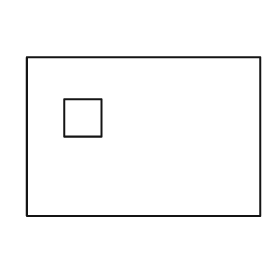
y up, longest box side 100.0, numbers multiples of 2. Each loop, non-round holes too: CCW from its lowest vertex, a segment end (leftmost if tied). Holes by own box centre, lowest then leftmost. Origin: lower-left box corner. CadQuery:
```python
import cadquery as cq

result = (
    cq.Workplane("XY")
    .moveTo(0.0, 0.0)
    .lineTo(100.0, 0.0)
    .lineTo(100.0, 68.0)
    .lineTo(0.0, 68.0)
    .close()
    .moveTo(16.0, 34.0)
    .lineTo(32.0, 34.0)
    .lineTo(32.0, 50.0)
    .lineTo(16.0, 50.0)
    .close()
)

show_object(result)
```